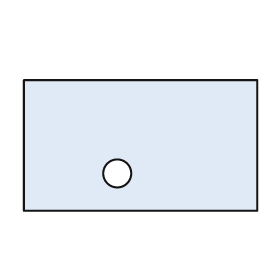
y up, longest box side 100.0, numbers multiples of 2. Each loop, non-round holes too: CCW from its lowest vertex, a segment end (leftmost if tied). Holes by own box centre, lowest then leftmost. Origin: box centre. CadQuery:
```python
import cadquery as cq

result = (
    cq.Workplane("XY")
    .moveTo(-50.0, -28.0)
    .lineTo(50.0, -28.0)
    .lineTo(50.0, 28.0)
    .lineTo(-50.0, 28.0)
    .close()
    .moveTo(-10.0, -12.0)
    .circle(6.0)
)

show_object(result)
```